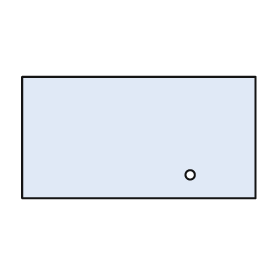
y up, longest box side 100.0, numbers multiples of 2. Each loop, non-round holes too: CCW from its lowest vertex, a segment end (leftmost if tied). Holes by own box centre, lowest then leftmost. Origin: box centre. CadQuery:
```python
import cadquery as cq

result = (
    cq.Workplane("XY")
    .moveTo(-50.0, -26.0)
    .lineTo(50.0, -26.0)
    .lineTo(50.0, 26.0)
    .lineTo(-50.0, 26.0)
    .close()
    .moveTo(22.0, -16.0)
    .circle(2.0)
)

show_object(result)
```